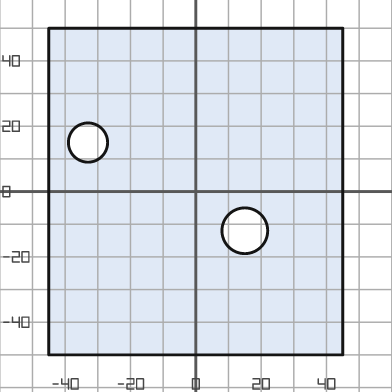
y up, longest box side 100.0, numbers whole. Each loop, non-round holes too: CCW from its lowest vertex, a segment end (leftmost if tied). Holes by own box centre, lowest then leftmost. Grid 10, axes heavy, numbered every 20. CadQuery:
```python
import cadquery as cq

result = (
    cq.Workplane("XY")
    .moveTo(-45.0, -50.0)
    .lineTo(45.0, -50.0)
    .lineTo(45.0, 50.0)
    .lineTo(-45.0, 50.0)
    .close()
    .moveTo(15.0, -12.0)
    .circle(7.0)
    .moveTo(-33.0, 15.0)
    .circle(6.0)
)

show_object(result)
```